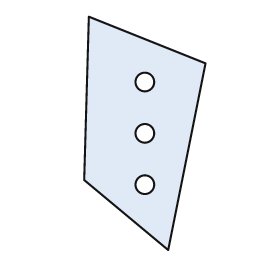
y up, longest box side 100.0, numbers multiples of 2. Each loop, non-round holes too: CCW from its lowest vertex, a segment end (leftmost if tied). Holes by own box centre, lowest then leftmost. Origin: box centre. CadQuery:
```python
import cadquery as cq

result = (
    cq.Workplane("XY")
    .moveTo(10.0, -50.0)
    .lineTo(26.0, 30.0)
    .lineTo(-24.0, 50.0)
    .lineTo(-26.0, -20.0)
    .close()
    .moveTo(0.0, -22.0)
    .circle(4.0)
    .moveTo(0.0, 0.0)
    .circle(4.0)
    .moveTo(0.0, 22.0)
    .circle(4.0)
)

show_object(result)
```